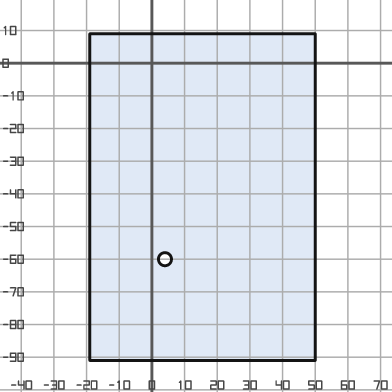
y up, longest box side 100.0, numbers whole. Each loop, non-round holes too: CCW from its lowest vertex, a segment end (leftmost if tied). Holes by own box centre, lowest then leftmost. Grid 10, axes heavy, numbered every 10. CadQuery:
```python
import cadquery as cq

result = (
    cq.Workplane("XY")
    .moveTo(-19.0, -91.0)
    .lineTo(50.0, -91.0)
    .lineTo(50.0, 9.0)
    .lineTo(-19.0, 9.0)
    .close()
    .moveTo(4.0, -60.0)
    .circle(2.0)
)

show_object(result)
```